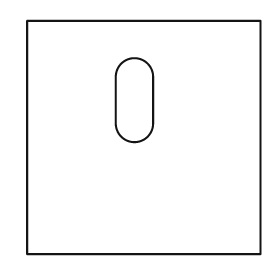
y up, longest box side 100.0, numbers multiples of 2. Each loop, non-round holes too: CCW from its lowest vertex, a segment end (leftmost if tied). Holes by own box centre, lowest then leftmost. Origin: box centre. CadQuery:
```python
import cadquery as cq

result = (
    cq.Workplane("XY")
    .moveTo(-50.0, -50.0)
    .lineTo(50.0, -50.0)
    .lineTo(50.0, 50.0)
    .lineTo(-50.0, 50.0)
    .close()
    .moveTo(-12.0, 6.0)
    .threePointArc((-4.0, -2.0), (4.0, 6.0))
    .lineTo(4.0, 26.0)
    .threePointArc((-4.0, 34.0), (-12.0, 26.0))
    .close()
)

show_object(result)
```